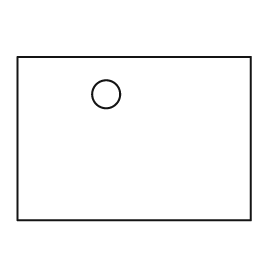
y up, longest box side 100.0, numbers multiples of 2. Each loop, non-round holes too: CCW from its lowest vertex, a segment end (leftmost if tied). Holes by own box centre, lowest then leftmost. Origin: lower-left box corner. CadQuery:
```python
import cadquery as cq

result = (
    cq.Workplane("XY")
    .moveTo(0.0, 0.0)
    .lineTo(100.0, 0.0)
    .lineTo(100.0, 70.0)
    .lineTo(0.0, 70.0)
    .close()
    .moveTo(38.0, 54.0)
    .circle(6.0)
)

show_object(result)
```